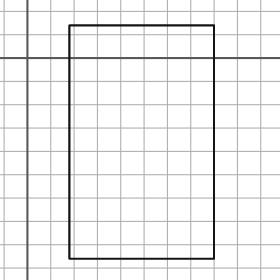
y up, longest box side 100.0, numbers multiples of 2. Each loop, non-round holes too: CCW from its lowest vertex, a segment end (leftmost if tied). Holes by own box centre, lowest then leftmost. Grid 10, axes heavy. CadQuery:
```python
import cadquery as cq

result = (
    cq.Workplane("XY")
    .moveTo(18.0, -86.0)
    .lineTo(80.0, -86.0)
    .lineTo(80.0, 14.0)
    .lineTo(18.0, 14.0)
    .close()
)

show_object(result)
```